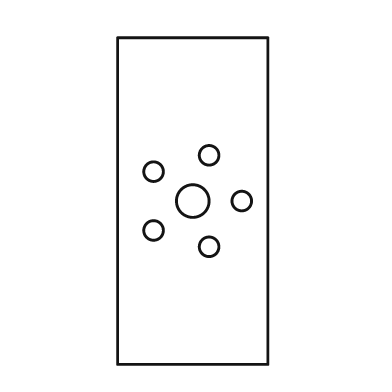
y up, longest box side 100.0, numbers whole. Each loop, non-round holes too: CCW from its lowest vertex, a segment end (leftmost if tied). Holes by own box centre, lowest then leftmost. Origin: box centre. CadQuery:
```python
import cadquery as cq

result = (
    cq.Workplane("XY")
    .moveTo(-23.0, -50.0)
    .lineTo(23.0, -50.0)
    .lineTo(23.0, 50.0)
    .lineTo(-23.0, 50.0)
    .close()
    .moveTo(5.0, -14.0)
    .circle(3.0)
    .moveTo(-12.0, -9.0)
    .circle(3.0)
    .moveTo(0.0, 0.0)
    .circle(5.0)
    .moveTo(15.0, 0.0)
    .circle(3.0)
    .moveTo(-12.0, 9.0)
    .circle(3.0)
    .moveTo(5.0, 14.0)
    .circle(3.0)
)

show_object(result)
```